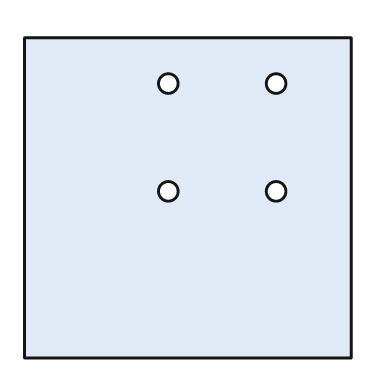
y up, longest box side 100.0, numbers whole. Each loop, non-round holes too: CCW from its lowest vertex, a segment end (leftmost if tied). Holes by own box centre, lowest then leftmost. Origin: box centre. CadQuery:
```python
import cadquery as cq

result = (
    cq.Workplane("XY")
    .moveTo(-50.0, -49.0)
    .lineTo(50.0, -49.0)
    .lineTo(50.0, 49.0)
    .lineTo(-50.0, 49.0)
    .close()
    .moveTo(-6.0, 2.0)
    .circle(3.0)
    .moveTo(27.0, 2.0)
    .circle(3.0)
    .moveTo(-6.0, 35.0)
    .circle(3.0)
    .moveTo(27.0, 35.0)
    .circle(3.0)
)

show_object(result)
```